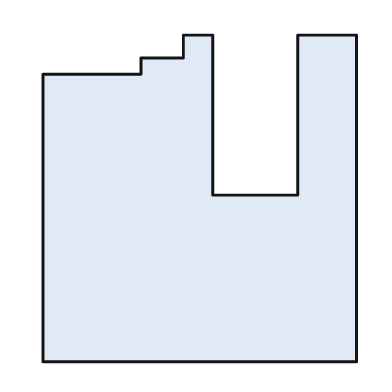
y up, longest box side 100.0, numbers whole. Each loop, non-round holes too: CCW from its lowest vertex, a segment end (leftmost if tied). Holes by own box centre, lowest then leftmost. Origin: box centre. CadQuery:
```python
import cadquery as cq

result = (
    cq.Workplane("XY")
    .moveTo(-48.0, -50.0)
    .lineTo(48.0, -50.0)
    .lineTo(48.0, 50.0)
    .lineTo(30.0, 50.0)
    .lineTo(30.0, 1.0)
    .lineTo(4.0, 1.0)
    .lineTo(4.0, 50.0)
    .lineTo(-5.0, 50.0)
    .lineTo(-5.0, 43.0)
    .lineTo(-18.0, 43.0)
    .lineTo(-18.0, 38.0)
    .lineTo(-48.0, 38.0)
    .close()
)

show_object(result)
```